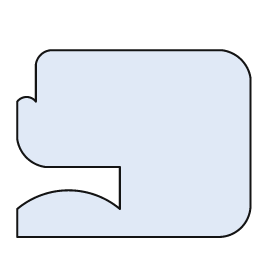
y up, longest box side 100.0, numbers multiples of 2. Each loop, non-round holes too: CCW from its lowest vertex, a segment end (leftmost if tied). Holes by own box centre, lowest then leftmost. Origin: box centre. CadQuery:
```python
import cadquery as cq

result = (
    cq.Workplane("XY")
    .moveTo(-50.0, -40.0)
    .lineTo(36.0, -40.0)
    .threePointArc((46.0, -36.0), (50.0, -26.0))
    .lineTo(50.0, 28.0)
    .threePointArc((46.0, 36.0), (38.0, 40.0))
    .lineTo(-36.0, 40.0)
    .threePointArc((-40.0, 38.0), (-42.0, 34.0))
    .lineTo(-42.0, 18.0)
    .threePointArc((-46.0, 20.0), (-50.0, 18.0))
    .lineTo(-50.0, 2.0)
    .threePointArc((-46.0, -6.0), (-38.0, -10.0))
    .lineTo(-6.0, -10.0)
    .lineTo(-6.0, -28.0)
    .threePointArc((-28.0, -20.0), (-50.0, -28.0))
    .close()
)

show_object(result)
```